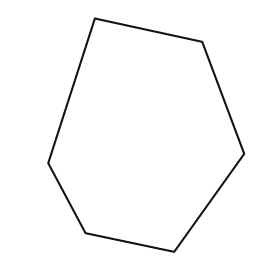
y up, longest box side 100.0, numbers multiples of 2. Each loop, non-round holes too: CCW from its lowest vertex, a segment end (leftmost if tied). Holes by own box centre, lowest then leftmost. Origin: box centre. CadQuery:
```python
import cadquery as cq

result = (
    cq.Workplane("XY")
    .moveTo(12.0, -50.0)
    .lineTo(42.0, -8.0)
    .lineTo(24.0, 40.0)
    .lineTo(-22.0, 50.0)
    .lineTo(-42.0, -12.0)
    .lineTo(-26.0, -42.0)
    .close()
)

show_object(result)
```